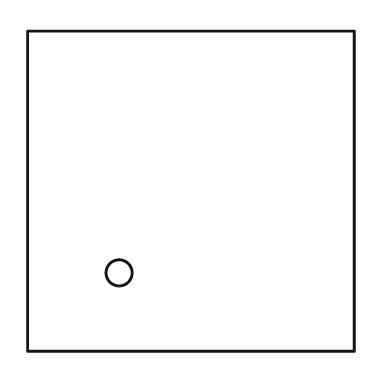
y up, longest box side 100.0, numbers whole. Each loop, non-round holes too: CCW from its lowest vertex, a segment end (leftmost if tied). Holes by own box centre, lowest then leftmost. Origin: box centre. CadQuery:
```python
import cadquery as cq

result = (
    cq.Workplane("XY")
    .moveTo(-50.0, -49.0)
    .lineTo(50.0, -49.0)
    .lineTo(50.0, 49.0)
    .lineTo(-50.0, 49.0)
    .close()
    .moveTo(-22.0, -25.0)
    .circle(4.0)
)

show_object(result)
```